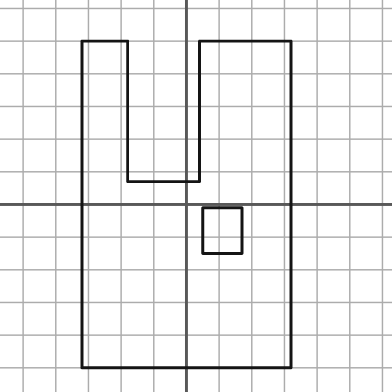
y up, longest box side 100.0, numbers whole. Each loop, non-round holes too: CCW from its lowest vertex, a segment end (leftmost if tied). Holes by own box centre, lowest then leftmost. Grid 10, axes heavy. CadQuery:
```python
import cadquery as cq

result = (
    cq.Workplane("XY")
    .moveTo(-32.0, -50.0)
    .lineTo(32.0, -50.0)
    .lineTo(32.0, 50.0)
    .lineTo(4.0, 50.0)
    .lineTo(4.0, 7.0)
    .lineTo(-18.0, 7.0)
    .lineTo(-18.0, 50.0)
    .lineTo(-32.0, 50.0)
    .close()
    .moveTo(5.0, -15.0)
    .lineTo(17.0, -15.0)
    .lineTo(17.0, -1.0)
    .lineTo(5.0, -1.0)
    .close()
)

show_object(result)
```